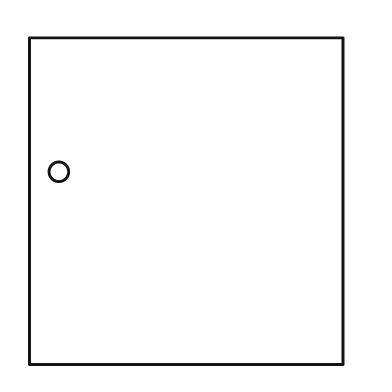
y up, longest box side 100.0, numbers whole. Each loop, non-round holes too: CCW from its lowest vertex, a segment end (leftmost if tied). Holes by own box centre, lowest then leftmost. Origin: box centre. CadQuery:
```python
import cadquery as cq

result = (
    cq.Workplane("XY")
    .moveTo(-48.0, -50.0)
    .lineTo(48.0, -50.0)
    .lineTo(48.0, 50.0)
    .lineTo(-48.0, 50.0)
    .close()
    .moveTo(-39.0, 9.0)
    .circle(3.0)
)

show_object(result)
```